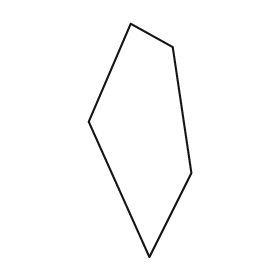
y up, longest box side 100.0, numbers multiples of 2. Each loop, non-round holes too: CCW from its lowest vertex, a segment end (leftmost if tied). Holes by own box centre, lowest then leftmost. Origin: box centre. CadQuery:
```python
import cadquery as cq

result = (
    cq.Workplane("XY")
    .moveTo(4.0, -50.0)
    .lineTo(22.0, -14.0)
    .lineTo(14.0, 40.0)
    .lineTo(-4.0, 50.0)
    .lineTo(-22.0, 8.0)
    .close()
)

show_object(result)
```